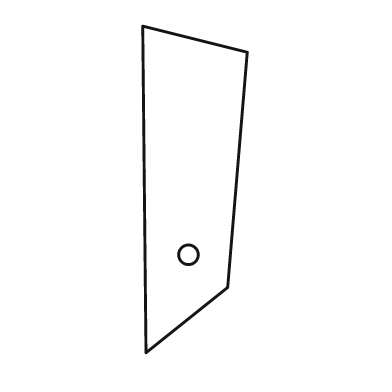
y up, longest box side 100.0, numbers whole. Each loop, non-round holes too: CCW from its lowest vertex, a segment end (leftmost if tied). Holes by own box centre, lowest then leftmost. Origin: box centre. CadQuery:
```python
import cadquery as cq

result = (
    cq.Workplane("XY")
    .moveTo(-15.0, -50.0)
    .lineTo(10.0, -30.0)
    .lineTo(16.0, 42.0)
    .lineTo(-16.0, 50.0)
    .close()
    .moveTo(-2.0, -20.0)
    .circle(3.0)
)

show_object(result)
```